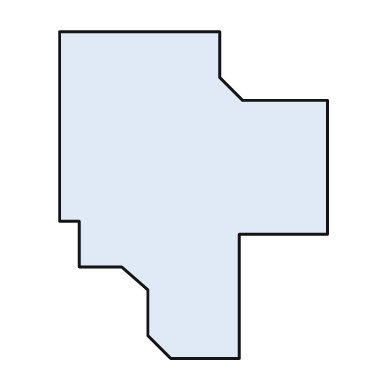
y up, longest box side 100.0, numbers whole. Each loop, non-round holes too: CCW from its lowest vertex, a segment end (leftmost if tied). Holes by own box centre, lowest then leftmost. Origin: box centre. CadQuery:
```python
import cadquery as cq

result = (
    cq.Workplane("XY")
    .moveTo(-7.0, -50.0)
    .lineTo(14.0, -50.0)
    .lineTo(14.0, -12.0)
    .lineTo(41.0, -12.0)
    .lineTo(41.0, 29.0)
    .lineTo(15.0, 29.0)
    .lineTo(8.0, 36.0)
    .lineTo(8.0, 50.0)
    .lineTo(-41.0, 50.0)
    .lineTo(-41.0, -8.0)
    .lineTo(-35.0, -8.0)
    .lineTo(-35.0, -22.0)
    .lineTo(-22.0, -22.0)
    .lineTo(-14.0, -29.0)
    .lineTo(-14.0, -43.0)
    .close()
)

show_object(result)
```